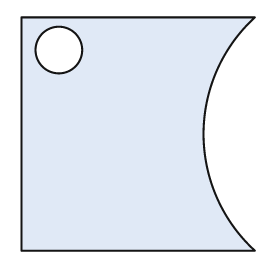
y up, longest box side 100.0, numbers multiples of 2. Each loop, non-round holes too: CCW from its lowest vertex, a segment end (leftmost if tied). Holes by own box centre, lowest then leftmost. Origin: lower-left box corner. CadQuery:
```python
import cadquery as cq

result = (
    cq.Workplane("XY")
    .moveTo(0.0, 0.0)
    .lineTo(100.0, 0.0)
    .threePointArc((78.0, 50.0), (100.0, 100.0))
    .lineTo(0.0, 100.0)
    .close()
    .moveTo(16.0, 86.0)
    .circle(10.0)
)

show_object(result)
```